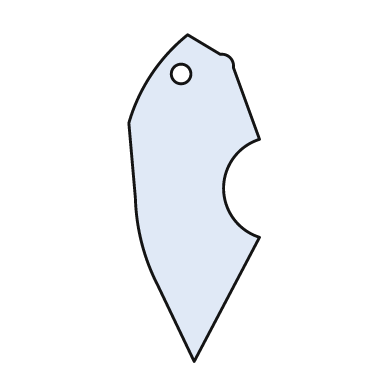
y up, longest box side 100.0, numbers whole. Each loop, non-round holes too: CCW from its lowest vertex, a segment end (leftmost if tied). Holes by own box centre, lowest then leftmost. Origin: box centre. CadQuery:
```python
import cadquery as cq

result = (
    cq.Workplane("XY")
    .moveTo(0.0, -50.0)
    .lineTo(20.0, -12.0)
    .threePointArc((9.0, 3.0), (20.0, 18.0))
    .lineTo(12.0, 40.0)
    .threePointArc((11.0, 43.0), (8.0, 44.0))
    .lineTo(-2.0, 50.0)
    .threePointArc((-13.0, 38.0), (-20.0, 23.0))
    .lineTo(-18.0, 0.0)
    .threePointArc((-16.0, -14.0), (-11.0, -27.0))
    .close()
    .moveTo(-4.0, 38.0)
    .circle(3.0)
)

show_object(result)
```